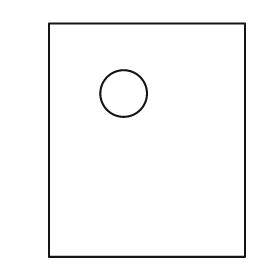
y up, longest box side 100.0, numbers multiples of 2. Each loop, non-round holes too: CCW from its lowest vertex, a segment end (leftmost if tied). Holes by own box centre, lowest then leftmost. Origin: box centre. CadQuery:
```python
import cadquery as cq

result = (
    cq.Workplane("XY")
    .moveTo(-42.0, -50.0)
    .lineTo(42.0, -50.0)
    .lineTo(42.0, 50.0)
    .lineTo(-42.0, 50.0)
    .close()
    .moveTo(-10.0, 20.0)
    .circle(10.0)
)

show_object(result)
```